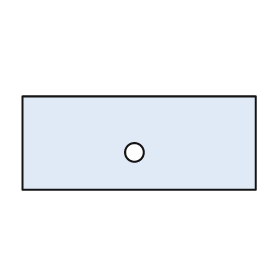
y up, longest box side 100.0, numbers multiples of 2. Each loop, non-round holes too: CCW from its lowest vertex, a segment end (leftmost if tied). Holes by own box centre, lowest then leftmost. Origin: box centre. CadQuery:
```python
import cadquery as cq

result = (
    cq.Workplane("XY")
    .moveTo(-50.0, -20.0)
    .lineTo(50.0, -20.0)
    .lineTo(50.0, 20.0)
    .lineTo(-50.0, 20.0)
    .close()
    .moveTo(-2.0, -4.0)
    .circle(4.0)
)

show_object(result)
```